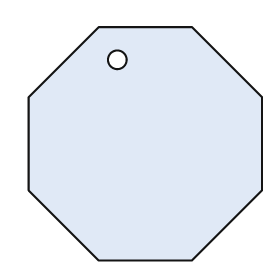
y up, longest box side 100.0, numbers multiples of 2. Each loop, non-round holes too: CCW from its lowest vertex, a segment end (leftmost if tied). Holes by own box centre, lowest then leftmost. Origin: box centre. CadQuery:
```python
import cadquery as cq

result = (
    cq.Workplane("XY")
    .moveTo(-20.0, -50.0)
    .lineTo(20.0, -50.0)
    .lineTo(50.0, -20.0)
    .lineTo(50.0, 20.0)
    .lineTo(20.0, 50.0)
    .lineTo(-20.0, 50.0)
    .lineTo(-50.0, 20.0)
    .lineTo(-50.0, -20.0)
    .close()
    .moveTo(-12.0, 36.0)
    .circle(4.0)
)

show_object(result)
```